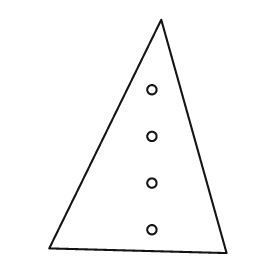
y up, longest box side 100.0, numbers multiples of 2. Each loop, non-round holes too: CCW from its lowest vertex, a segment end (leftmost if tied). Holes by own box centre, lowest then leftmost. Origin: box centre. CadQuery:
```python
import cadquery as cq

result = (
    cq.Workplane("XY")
    .moveTo(38.0, -50.0)
    .lineTo(10.0, 50.0)
    .lineTo(-38.0, -48.0)
    .close()
    .moveTo(6.0, -40.0)
    .circle(2.0)
    .moveTo(6.0, -20.0)
    .circle(2.0)
    .moveTo(6.0, 0.0)
    .circle(2.0)
    .moveTo(6.0, 20.0)
    .circle(2.0)
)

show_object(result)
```